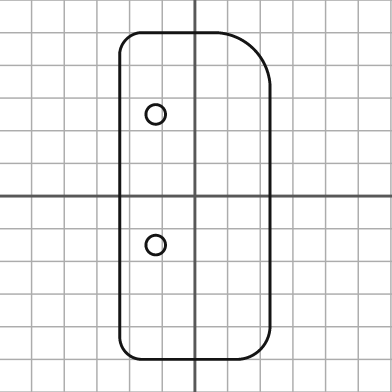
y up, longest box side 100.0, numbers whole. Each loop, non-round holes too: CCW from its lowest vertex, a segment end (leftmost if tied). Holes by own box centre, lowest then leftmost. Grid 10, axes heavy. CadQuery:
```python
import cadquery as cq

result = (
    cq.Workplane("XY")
    .moveTo(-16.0, -50.0)
    .lineTo(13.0, -50.0)
    .threePointArc((20.0, -47.0), (23.0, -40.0))
    .lineTo(23.0, 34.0)
    .threePointArc((18.0, 45.0), (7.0, 50.0))
    .lineTo(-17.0, 50.0)
    .threePointArc((-21.0, 48.0), (-23.0, 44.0))
    .lineTo(-23.0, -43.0)
    .threePointArc((-21.0, -48.0), (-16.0, -50.0))
    .close()
    .moveTo(-12.0, -15.0)
    .circle(3.0)
    .moveTo(-12.0, 25.0)
    .circle(3.0)
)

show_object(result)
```